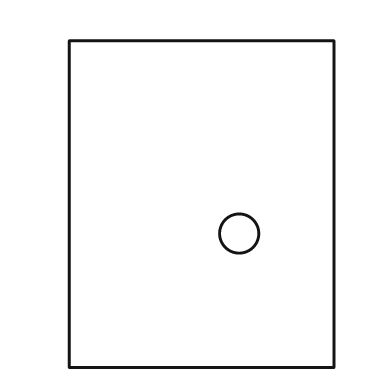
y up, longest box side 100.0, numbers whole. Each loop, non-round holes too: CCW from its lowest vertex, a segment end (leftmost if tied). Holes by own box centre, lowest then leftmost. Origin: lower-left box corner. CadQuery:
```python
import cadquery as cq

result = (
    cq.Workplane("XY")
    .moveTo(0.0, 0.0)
    .lineTo(81.0, 0.0)
    .lineTo(81.0, 100.0)
    .lineTo(0.0, 100.0)
    .close()
    .moveTo(52.0, 41.0)
    .circle(6.0)
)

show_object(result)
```